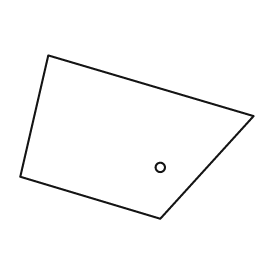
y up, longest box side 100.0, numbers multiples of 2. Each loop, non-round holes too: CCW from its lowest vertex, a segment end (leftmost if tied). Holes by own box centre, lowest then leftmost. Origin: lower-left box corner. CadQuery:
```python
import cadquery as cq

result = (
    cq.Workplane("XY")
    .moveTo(60.0, 0.0)
    .lineTo(100.0, 44.0)
    .lineTo(12.0, 70.0)
    .lineTo(0.0, 18.0)
    .close()
    .moveTo(60.0, 22.0)
    .circle(2.0)
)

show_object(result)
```